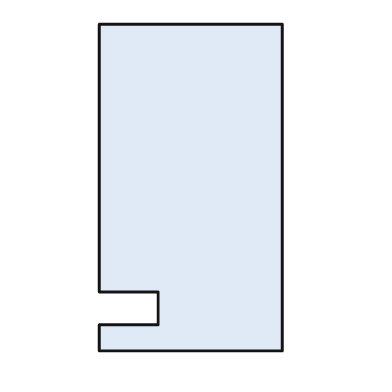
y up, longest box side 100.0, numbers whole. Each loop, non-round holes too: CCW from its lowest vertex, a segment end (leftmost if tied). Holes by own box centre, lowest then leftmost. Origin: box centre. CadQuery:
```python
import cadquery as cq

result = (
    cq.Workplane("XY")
    .moveTo(-28.0, -50.0)
    .lineTo(28.0, -50.0)
    .lineTo(28.0, 50.0)
    .lineTo(-28.0, 50.0)
    .lineTo(-28.0, -32.0)
    .lineTo(-10.0, -32.0)
    .lineTo(-10.0, -42.0)
    .lineTo(-28.0, -42.0)
    .close()
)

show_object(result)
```